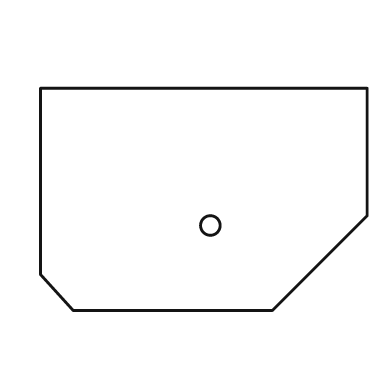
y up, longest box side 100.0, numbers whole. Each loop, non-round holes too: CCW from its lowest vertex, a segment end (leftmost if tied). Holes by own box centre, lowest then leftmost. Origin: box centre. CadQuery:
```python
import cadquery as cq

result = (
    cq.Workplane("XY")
    .moveTo(-40.0, -34.0)
    .lineTo(21.0, -34.0)
    .lineTo(50.0, -5.0)
    .lineTo(50.0, 34.0)
    .lineTo(-50.0, 34.0)
    .lineTo(-50.0, -23.0)
    .close()
    .moveTo(2.0, -8.0)
    .circle(3.0)
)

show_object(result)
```